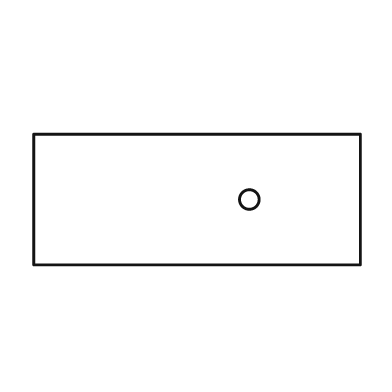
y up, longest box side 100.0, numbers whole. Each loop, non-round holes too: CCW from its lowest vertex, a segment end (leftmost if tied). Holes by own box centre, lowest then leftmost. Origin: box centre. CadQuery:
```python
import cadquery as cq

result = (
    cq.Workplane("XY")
    .moveTo(-50.0, -20.0)
    .lineTo(50.0, -20.0)
    .lineTo(50.0, 20.0)
    .lineTo(-50.0, 20.0)
    .close()
    .moveTo(16.0, 0.0)
    .circle(3.0)
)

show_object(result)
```